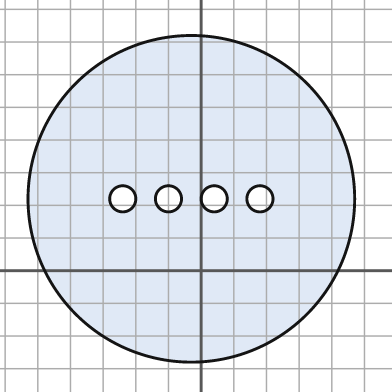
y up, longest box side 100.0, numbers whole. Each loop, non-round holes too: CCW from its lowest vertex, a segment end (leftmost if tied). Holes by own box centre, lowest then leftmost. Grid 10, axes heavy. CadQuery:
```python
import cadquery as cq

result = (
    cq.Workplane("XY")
    .moveTo(-3.0, 22.0)
    .circle(50.0)
    .moveTo(-24.0, 22.0)
    .circle(4.0)
    .moveTo(-10.0, 22.0)
    .circle(4.0)
    .moveTo(4.0, 22.0)
    .circle(4.0)
    .moveTo(18.0, 22.0)
    .circle(4.0)
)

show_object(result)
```